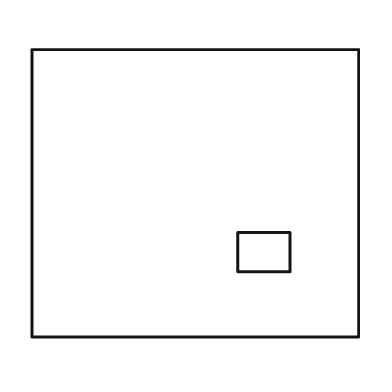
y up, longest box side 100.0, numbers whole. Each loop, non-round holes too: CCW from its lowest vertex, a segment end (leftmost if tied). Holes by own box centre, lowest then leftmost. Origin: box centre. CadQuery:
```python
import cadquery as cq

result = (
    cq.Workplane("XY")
    .moveTo(-50.0, -44.0)
    .lineTo(50.0, -44.0)
    .lineTo(50.0, 44.0)
    .lineTo(-50.0, 44.0)
    .close()
    .moveTo(13.0, -24.0)
    .lineTo(29.0, -24.0)
    .lineTo(29.0, -12.0)
    .lineTo(13.0, -12.0)
    .close()
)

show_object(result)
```